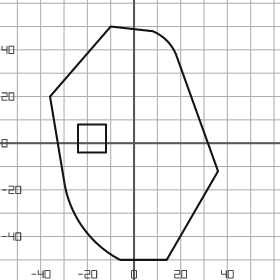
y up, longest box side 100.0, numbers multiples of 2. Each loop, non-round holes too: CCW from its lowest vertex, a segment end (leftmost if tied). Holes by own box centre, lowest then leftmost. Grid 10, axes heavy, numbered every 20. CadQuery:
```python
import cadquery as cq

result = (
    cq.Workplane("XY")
    .moveTo(-6.0, -50.0)
    .lineTo(14.0, -50.0)
    .lineTo(36.0, -12.0)
    .lineTo(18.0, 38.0)
    .threePointArc((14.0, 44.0), (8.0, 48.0))
    .lineTo(-10.0, 50.0)
    .lineTo(-36.0, 20.0)
    .lineTo(-30.0, -16.0)
    .threePointArc((-22.0, -36.0), (-6.0, -50.0))
    .close()
    .moveTo(-24.0, -4.0)
    .lineTo(-12.0, -4.0)
    .lineTo(-12.0, 8.0)
    .lineTo(-24.0, 8.0)
    .close()
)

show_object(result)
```